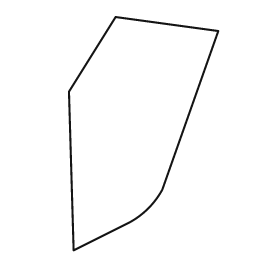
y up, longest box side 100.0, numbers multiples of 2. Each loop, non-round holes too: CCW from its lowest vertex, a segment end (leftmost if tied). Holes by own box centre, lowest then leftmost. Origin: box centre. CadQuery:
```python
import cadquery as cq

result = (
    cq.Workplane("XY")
    .moveTo(-30.0, -50.0)
    .lineTo(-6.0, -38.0)
    .threePointArc((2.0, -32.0), (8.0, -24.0))
    .lineTo(32.0, 44.0)
    .lineTo(-12.0, 50.0)
    .lineTo(-32.0, 18.0)
    .close()
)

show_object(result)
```